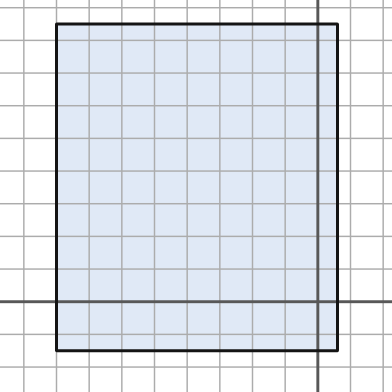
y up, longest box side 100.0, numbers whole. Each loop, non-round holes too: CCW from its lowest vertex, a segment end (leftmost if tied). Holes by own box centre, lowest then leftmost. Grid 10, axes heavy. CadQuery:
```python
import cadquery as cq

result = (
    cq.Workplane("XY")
    .moveTo(-80.0, -15.0)
    .lineTo(6.0, -15.0)
    .lineTo(6.0, 85.0)
    .lineTo(-80.0, 85.0)
    .close()
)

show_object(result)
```